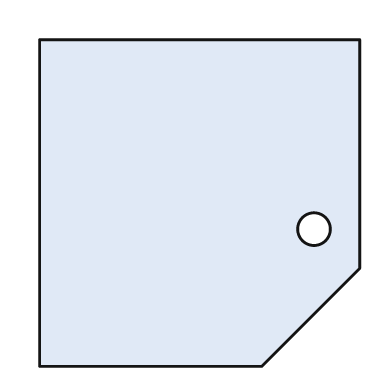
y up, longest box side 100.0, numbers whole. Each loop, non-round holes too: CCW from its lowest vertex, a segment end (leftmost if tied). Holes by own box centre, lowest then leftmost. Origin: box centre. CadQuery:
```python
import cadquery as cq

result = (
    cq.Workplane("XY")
    .moveTo(-49.0, -50.0)
    .lineTo(19.0, -50.0)
    .lineTo(49.0, -20.0)
    .lineTo(49.0, 50.0)
    .lineTo(-49.0, 50.0)
    .close()
    .moveTo(35.0, -8.0)
    .circle(5.0)
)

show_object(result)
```